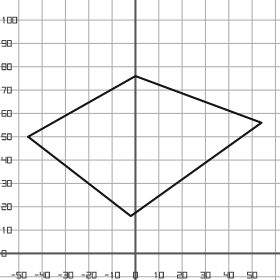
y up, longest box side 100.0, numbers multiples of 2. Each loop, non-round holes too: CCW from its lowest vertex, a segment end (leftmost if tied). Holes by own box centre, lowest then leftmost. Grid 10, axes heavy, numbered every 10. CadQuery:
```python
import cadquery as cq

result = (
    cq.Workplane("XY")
    .moveTo(-2.0, 16.0)
    .lineTo(54.0, 56.0)
    .lineTo(0.0, 76.0)
    .lineTo(-46.0, 50.0)
    .close()
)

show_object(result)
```